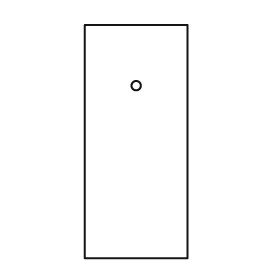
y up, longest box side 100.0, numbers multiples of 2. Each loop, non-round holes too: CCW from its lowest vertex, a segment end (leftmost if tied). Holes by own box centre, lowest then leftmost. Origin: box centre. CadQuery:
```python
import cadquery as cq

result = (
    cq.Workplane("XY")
    .moveTo(-22.0, -50.0)
    .lineTo(22.0, -50.0)
    .lineTo(22.0, 50.0)
    .lineTo(-22.0, 50.0)
    .close()
    .moveTo(0.0, 24.0)
    .circle(2.0)
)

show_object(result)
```